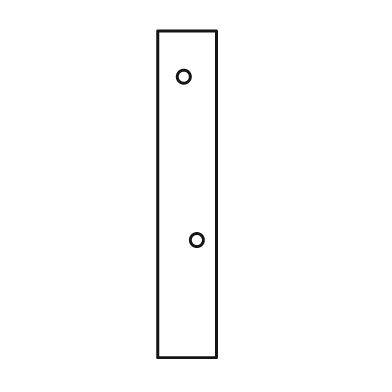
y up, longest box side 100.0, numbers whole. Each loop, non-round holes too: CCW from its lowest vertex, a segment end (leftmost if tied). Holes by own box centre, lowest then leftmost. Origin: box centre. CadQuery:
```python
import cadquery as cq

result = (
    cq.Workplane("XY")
    .moveTo(-9.0, -50.0)
    .lineTo(9.0, -50.0)
    .lineTo(9.0, 50.0)
    .lineTo(-9.0, 50.0)
    .close()
    .moveTo(3.0, -14.0)
    .circle(2.0)
    .moveTo(-1.0, 36.0)
    .circle(2.0)
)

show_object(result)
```